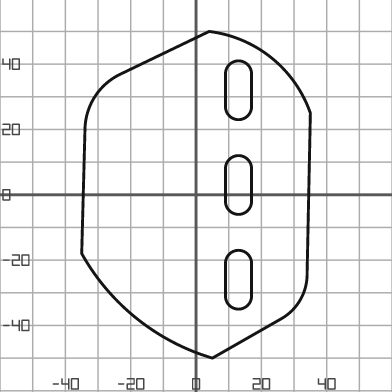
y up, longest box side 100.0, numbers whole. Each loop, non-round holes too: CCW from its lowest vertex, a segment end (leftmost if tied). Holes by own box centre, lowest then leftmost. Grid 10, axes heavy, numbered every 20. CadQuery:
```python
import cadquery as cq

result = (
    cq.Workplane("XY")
    .moveTo(5.0, -50.0)
    .lineTo(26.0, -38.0)
    .threePointArc((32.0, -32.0), (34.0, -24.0))
    .lineTo(35.0, 25.0)
    .threePointArc((23.0, 42.0), (4.0, 50.0))
    .lineTo(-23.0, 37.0)
    .threePointArc((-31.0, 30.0), (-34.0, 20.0))
    .lineTo(-35.0, -18.0)
    .threePointArc((-18.0, -38.0), (5.0, -50.0))
    .close()
    .moveTo(9.0, -31.0)
    .threePointArc((13.0, -35.0), (17.0, -31.0))
    .lineTo(17.0, -21.0)
    .threePointArc((13.0, -17.0), (9.0, -21.0))
    .close()
    .moveTo(9.0, -2.0)
    .threePointArc((13.0, -6.0), (17.0, -2.0))
    .lineTo(17.0, 8.0)
    .threePointArc((13.0, 12.0), (9.0, 8.0))
    .close()
    .moveTo(9.0, 27.0)
    .threePointArc((13.0, 23.0), (17.0, 27.0))
    .lineTo(17.0, 37.0)
    .threePointArc((13.0, 41.0), (9.0, 37.0))
    .close()
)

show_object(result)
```